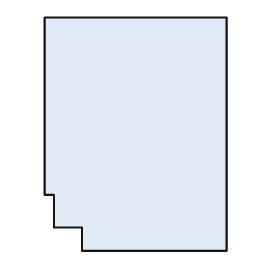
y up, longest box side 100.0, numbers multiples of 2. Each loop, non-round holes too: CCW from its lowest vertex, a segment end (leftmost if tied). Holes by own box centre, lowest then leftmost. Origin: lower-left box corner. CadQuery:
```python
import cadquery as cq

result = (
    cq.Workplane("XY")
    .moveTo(16.0, 0.0)
    .lineTo(78.0, 0.0)
    .lineTo(78.0, 100.0)
    .lineTo(0.0, 100.0)
    .lineTo(0.0, 24.0)
    .lineTo(4.0, 24.0)
    .lineTo(4.0, 10.0)
    .lineTo(16.0, 10.0)
    .close()
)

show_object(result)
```